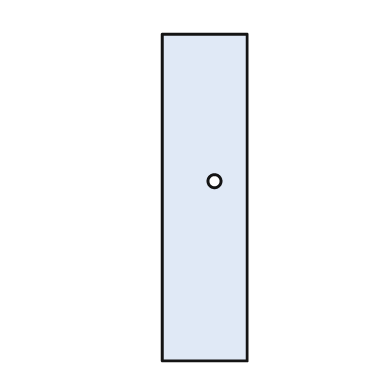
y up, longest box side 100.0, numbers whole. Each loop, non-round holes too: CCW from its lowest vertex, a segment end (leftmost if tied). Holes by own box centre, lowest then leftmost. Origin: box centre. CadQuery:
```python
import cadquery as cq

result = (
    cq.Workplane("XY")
    .moveTo(-13.0, -50.0)
    .lineTo(13.0, -50.0)
    .lineTo(13.0, 50.0)
    .lineTo(-13.0, 50.0)
    .close()
    .moveTo(3.0, 5.0)
    .circle(2.0)
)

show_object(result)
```